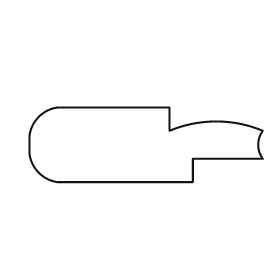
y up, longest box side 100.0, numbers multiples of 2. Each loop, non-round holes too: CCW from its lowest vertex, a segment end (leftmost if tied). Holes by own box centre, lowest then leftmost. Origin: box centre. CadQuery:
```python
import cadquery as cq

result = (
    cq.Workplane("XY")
    .moveTo(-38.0, -16.0)
    .lineTo(20.0, -16.0)
    .lineTo(20.0, -6.0)
    .lineTo(50.0, -6.0)
    .threePointArc((48.0, 0.0), (50.0, 6.0))
    .threePointArc((30.0, 10.0), (10.0, 6.0))
    .lineTo(10.0, 16.0)
    .lineTo(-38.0, 16.0)
    .threePointArc((-46.0, 12.0), (-50.0, 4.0))
    .lineTo(-50.0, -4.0)
    .threePointArc((-46.0, -12.0), (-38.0, -16.0))
    .close()
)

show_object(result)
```